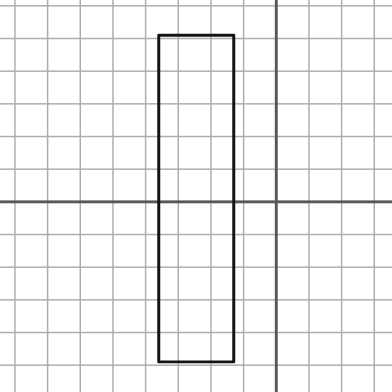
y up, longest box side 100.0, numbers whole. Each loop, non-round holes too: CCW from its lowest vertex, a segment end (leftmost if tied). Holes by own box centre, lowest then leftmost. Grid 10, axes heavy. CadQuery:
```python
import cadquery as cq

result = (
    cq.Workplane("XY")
    .moveTo(-36.0, -49.0)
    .lineTo(-13.0, -49.0)
    .lineTo(-13.0, 51.0)
    .lineTo(-36.0, 51.0)
    .close()
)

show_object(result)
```